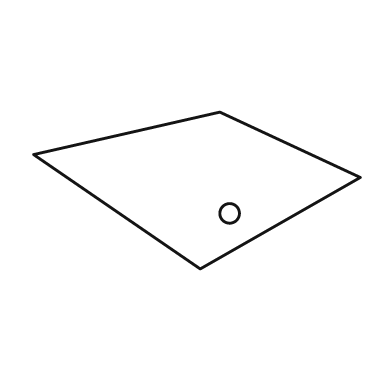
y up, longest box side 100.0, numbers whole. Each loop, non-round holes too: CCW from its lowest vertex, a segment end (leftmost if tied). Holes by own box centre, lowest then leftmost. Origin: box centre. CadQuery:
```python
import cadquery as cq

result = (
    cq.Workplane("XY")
    .moveTo(1.0, -24.0)
    .lineTo(50.0, 4.0)
    .lineTo(7.0, 24.0)
    .lineTo(-50.0, 11.0)
    .close()
    .moveTo(10.0, -7.0)
    .circle(3.0)
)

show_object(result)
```